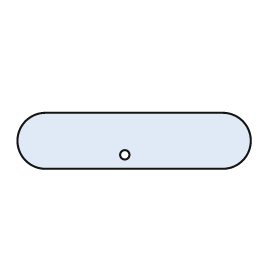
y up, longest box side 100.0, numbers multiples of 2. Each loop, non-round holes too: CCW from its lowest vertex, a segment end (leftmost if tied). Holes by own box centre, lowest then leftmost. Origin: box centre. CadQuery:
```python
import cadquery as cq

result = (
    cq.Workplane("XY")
    .moveTo(-38.0, -12.0)
    .lineTo(38.0, -12.0)
    .threePointArc((50.0, 0.0), (38.0, 12.0))
    .lineTo(-38.0, 12.0)
    .threePointArc((-50.0, 0.0), (-38.0, -12.0))
    .close()
    .moveTo(-4.0, -6.0)
    .circle(2.0)
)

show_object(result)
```